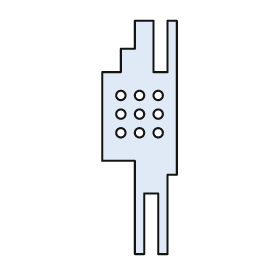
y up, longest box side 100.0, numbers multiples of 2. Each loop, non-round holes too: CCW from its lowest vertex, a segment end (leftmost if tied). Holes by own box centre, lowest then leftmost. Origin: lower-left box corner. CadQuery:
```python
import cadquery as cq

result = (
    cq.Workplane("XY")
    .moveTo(14.0, 0.0)
    .lineTo(18.0, 0.0)
    .lineTo(18.0, 26.0)
    .lineTo(24.0, 26.0)
    .lineTo(24.0, 0.0)
    .lineTo(28.0, 0.0)
    .lineTo(28.0, 34.0)
    .lineTo(32.0, 34.0)
    .lineTo(32.0, 100.0)
    .lineTo(28.0, 100.0)
    .lineTo(28.0, 78.0)
    .lineTo(22.0, 78.0)
    .lineTo(22.0, 100.0)
    .lineTo(14.0, 100.0)
    .lineTo(14.0, 88.0)
    .lineTo(8.0, 88.0)
    .lineTo(8.0, 78.0)
    .lineTo(0.0, 78.0)
    .lineTo(0.0, 40.0)
    .lineTo(14.0, 40.0)
    .close()
    .moveTo(8.0, 52.0)
    .circle(2.0)
    .moveTo(16.0, 52.0)
    .circle(2.0)
    .moveTo(24.0, 52.0)
    .circle(2.0)
    .moveTo(8.0, 60.0)
    .circle(2.0)
    .moveTo(16.0, 60.0)
    .circle(2.0)
    .moveTo(24.0, 60.0)
    .circle(2.0)
    .moveTo(8.0, 68.0)
    .circle(2.0)
    .moveTo(16.0, 68.0)
    .circle(2.0)
    .moveTo(24.0, 68.0)
    .circle(2.0)
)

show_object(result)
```